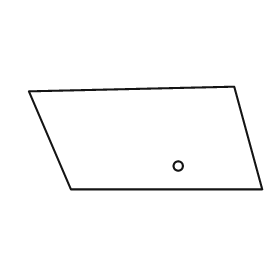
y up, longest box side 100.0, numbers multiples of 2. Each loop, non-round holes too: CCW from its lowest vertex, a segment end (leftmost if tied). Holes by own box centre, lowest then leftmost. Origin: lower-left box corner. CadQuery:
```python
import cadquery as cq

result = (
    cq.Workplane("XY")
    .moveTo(18.0, 0.0)
    .lineTo(100.0, 0.0)
    .lineTo(88.0, 44.0)
    .lineTo(0.0, 42.0)
    .close()
    .moveTo(64.0, 10.0)
    .circle(2.0)
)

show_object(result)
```